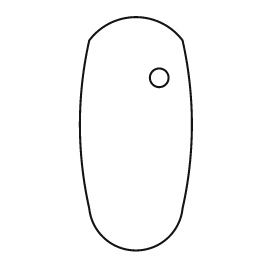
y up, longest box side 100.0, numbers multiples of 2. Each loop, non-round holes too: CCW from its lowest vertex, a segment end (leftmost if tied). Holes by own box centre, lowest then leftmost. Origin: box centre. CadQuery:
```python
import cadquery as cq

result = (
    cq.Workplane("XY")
    .moveTo(-20.0, -32.0)
    .threePointArc((0.0, -50.0), (20.0, -32.0))
    .threePointArc((24.0, 4.0), (20.0, 40.0))
    .threePointArc((0.0, 50.0), (-20.0, 40.0))
    .threePointArc((-24.0, 4.0), (-20.0, -32.0))
    .close()
    .moveTo(10.0, 24.0)
    .circle(4.0)
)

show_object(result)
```